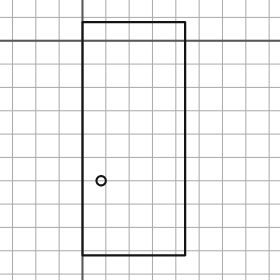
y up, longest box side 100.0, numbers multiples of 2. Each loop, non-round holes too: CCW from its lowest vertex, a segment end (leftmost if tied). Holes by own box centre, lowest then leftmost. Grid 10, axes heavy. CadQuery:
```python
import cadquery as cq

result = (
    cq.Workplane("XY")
    .moveTo(0.0, -92.0)
    .lineTo(44.0, -92.0)
    .lineTo(44.0, 8.0)
    .lineTo(0.0, 8.0)
    .close()
    .moveTo(8.0, -60.0)
    .circle(2.0)
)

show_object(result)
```